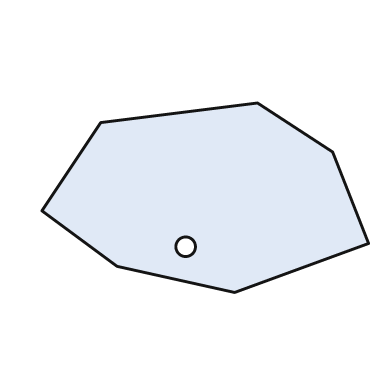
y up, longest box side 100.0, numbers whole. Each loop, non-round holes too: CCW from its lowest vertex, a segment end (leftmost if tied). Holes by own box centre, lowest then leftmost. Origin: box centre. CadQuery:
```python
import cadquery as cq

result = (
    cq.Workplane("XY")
    .moveTo(9.0, -29.0)
    .lineTo(50.0, -14.0)
    .lineTo(39.0, 14.0)
    .lineTo(16.0, 29.0)
    .lineTo(-32.0, 23.0)
    .lineTo(-50.0, -4.0)
    .lineTo(-27.0, -21.0)
    .close()
    .moveTo(-6.0, -15.0)
    .circle(3.0)
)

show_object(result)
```